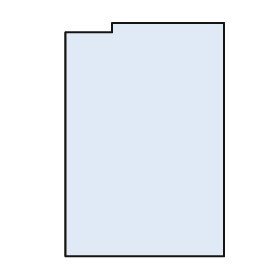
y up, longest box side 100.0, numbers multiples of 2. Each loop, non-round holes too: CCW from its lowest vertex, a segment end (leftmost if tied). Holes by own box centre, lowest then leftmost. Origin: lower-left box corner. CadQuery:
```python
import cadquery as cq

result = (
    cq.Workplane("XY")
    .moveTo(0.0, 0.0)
    .lineTo(68.0, 0.0)
    .lineTo(68.0, 100.0)
    .lineTo(20.0, 100.0)
    .lineTo(20.0, 96.0)
    .lineTo(0.0, 96.0)
    .close()
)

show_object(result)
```